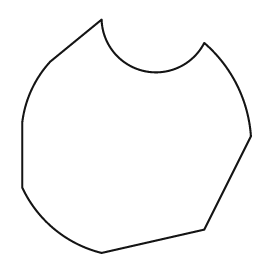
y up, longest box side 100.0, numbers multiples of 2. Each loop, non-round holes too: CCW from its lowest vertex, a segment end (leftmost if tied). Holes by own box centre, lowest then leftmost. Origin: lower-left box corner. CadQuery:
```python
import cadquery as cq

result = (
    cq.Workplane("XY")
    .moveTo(34.0, 0.0)
    .lineTo(78.0, 10.0)
    .lineTo(98.0, 50.0)
    .threePointArc((92.0, 72.0), (78.0, 90.0))
    .threePointArc((52.0, 78.0), (34.0, 100.0))
    .lineTo(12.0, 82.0)
    .threePointArc((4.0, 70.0), (0.0, 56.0))
    .lineTo(0.0, 28.0)
    .threePointArc((14.0, 10.0), (34.0, 0.0))
    .close()
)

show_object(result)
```